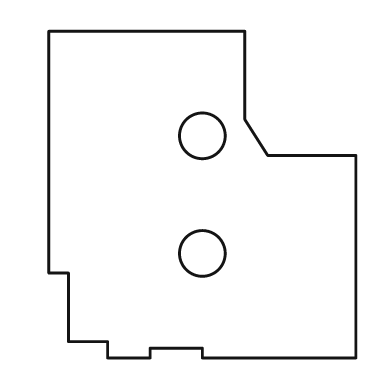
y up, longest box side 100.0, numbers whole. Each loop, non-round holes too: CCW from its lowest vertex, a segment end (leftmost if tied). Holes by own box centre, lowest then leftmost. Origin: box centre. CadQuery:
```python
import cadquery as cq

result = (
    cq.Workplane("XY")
    .moveTo(-29.0, -50.0)
    .lineTo(-16.0, -50.0)
    .lineTo(-16.0, -47.0)
    .lineTo(0.0, -47.0)
    .lineTo(0.0, -50.0)
    .lineTo(47.0, -50.0)
    .lineTo(47.0, 12.0)
    .lineTo(20.0, 12.0)
    .lineTo(13.0, 23.0)
    .lineTo(13.0, 50.0)
    .lineTo(-47.0, 50.0)
    .lineTo(-47.0, -24.0)
    .lineTo(-41.0, -24.0)
    .lineTo(-41.0, -45.0)
    .lineTo(-29.0, -45.0)
    .close()
    .moveTo(0.0, -18.0)
    .circle(7.0)
    .moveTo(0.0, 18.0)
    .circle(7.0)
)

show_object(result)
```